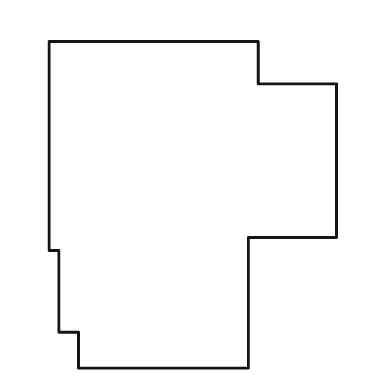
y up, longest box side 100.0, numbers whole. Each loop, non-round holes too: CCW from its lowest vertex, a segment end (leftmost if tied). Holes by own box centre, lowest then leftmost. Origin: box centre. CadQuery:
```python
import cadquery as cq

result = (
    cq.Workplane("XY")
    .moveTo(-35.0, -50.0)
    .lineTo(17.0, -50.0)
    .lineTo(17.0, -10.0)
    .lineTo(44.0, -10.0)
    .lineTo(44.0, 37.0)
    .lineTo(20.0, 37.0)
    .lineTo(20.0, 50.0)
    .lineTo(-44.0, 50.0)
    .lineTo(-44.0, -14.0)
    .lineTo(-41.0, -14.0)
    .lineTo(-41.0, -39.0)
    .lineTo(-35.0, -39.0)
    .close()
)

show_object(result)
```